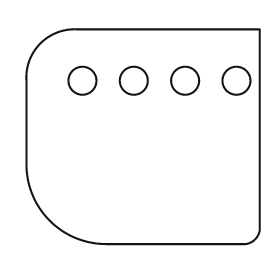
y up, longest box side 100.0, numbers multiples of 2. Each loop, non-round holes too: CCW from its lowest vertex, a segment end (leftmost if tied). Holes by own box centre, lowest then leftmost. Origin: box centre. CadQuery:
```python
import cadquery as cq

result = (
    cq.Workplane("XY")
    .moveTo(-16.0, -46.0)
    .lineTo(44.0, -46.0)
    .threePointArc((48.0, -44.0), (50.0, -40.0))
    .lineTo(50.0, 46.0)
    .lineTo(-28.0, 46.0)
    .threePointArc((-44.0, 40.0), (-50.0, 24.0))
    .lineTo(-50.0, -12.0)
    .threePointArc((-40.0, -36.0), (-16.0, -46.0))
    .close()
    .moveTo(-26.0, 24.0)
    .circle(6.0)
    .moveTo(-4.0, 24.0)
    .circle(6.0)
    .moveTo(18.0, 24.0)
    .circle(6.0)
    .moveTo(40.0, 24.0)
    .circle(6.0)
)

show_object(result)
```